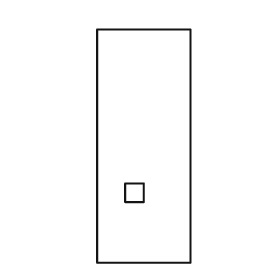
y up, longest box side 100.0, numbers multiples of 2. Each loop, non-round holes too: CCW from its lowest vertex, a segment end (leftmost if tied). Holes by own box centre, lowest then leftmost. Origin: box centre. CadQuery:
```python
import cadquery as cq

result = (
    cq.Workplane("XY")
    .moveTo(-20.0, -50.0)
    .lineTo(20.0, -50.0)
    .lineTo(20.0, 50.0)
    .lineTo(-20.0, 50.0)
    .close()
    .moveTo(-8.0, -24.0)
    .lineTo(0.0, -24.0)
    .lineTo(0.0, -16.0)
    .lineTo(-8.0, -16.0)
    .close()
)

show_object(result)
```